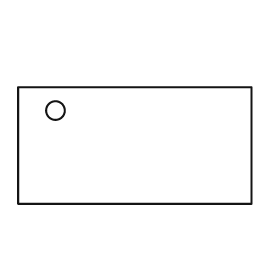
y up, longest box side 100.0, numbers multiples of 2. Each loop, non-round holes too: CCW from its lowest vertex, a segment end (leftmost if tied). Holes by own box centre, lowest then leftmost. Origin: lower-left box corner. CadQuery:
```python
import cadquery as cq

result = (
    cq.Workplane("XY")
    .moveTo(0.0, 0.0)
    .lineTo(100.0, 0.0)
    .lineTo(100.0, 50.0)
    .lineTo(0.0, 50.0)
    .close()
    .moveTo(16.0, 40.0)
    .circle(4.0)
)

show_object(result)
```